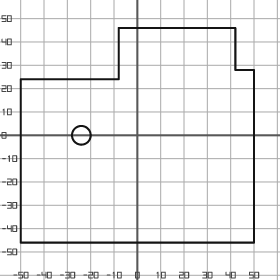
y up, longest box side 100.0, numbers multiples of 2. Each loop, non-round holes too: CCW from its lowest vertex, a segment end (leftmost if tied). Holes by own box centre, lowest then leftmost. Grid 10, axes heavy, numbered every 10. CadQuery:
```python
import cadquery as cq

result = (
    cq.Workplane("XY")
    .moveTo(-50.0, -46.0)
    .lineTo(50.0, -46.0)
    .lineTo(50.0, 28.0)
    .lineTo(42.0, 28.0)
    .lineTo(42.0, 46.0)
    .lineTo(-8.0, 46.0)
    .lineTo(-8.0, 24.0)
    .lineTo(-50.0, 24.0)
    .close()
    .moveTo(-24.0, 0.0)
    .circle(4.0)
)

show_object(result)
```